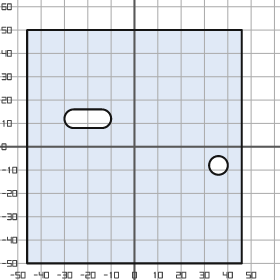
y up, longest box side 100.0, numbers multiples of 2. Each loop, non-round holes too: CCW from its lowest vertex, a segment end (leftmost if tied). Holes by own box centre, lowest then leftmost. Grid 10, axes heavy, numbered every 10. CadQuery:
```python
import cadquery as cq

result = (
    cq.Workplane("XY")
    .moveTo(-46.0, -50.0)
    .lineTo(46.0, -50.0)
    .lineTo(46.0, 50.0)
    .lineTo(-46.0, 50.0)
    .close()
    .moveTo(36.0, -8.0)
    .circle(4.0)
    .moveTo(-26.0, 8.0)
    .lineTo(-14.0, 8.0)
    .threePointArc((-10.0, 12.0), (-14.0, 16.0))
    .lineTo(-26.0, 16.0)
    .threePointArc((-30.0, 12.0), (-26.0, 8.0))
    .close()
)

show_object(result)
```